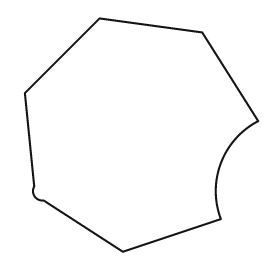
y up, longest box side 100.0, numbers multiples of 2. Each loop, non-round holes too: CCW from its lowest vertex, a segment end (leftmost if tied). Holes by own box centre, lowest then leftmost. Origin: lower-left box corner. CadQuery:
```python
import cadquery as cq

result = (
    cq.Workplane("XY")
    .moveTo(42.0, 0.0)
    .lineTo(84.0, 14.0)
    .threePointArc((84.0, 38.0), (100.0, 56.0))
    .lineTo(76.0, 94.0)
    .lineTo(32.0, 100.0)
    .lineTo(0.0, 68.0)
    .lineTo(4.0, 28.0)
    .threePointArc((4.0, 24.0), (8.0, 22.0))
    .close()
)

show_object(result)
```